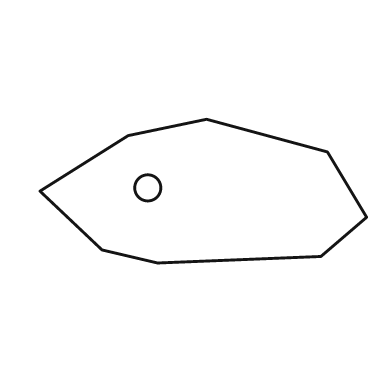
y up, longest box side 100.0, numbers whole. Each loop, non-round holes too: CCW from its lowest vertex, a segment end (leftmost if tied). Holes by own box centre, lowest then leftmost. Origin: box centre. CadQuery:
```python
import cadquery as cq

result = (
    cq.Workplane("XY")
    .moveTo(-14.0, -22.0)
    .lineTo(36.0, -20.0)
    .lineTo(50.0, -8.0)
    .lineTo(38.0, 12.0)
    .lineTo(1.0, 22.0)
    .lineTo(-23.0, 17.0)
    .lineTo(-50.0, 0.0)
    .lineTo(-31.0, -18.0)
    .close()
    .moveTo(-17.0, 1.0)
    .circle(4.0)
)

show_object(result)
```